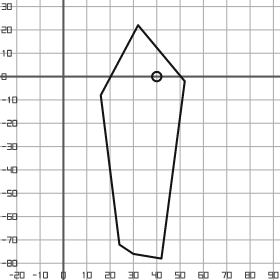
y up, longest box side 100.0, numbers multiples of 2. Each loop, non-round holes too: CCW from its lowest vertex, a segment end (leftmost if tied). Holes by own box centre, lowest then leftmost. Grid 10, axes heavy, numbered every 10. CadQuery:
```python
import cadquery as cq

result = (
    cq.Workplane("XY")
    .moveTo(42.0, -78.0)
    .lineTo(52.0, -2.0)
    .lineTo(32.0, 22.0)
    .lineTo(16.0, -8.0)
    .lineTo(24.0, -72.0)
    .lineTo(30.0, -76.0)
    .close()
    .moveTo(40.0, 0.0)
    .circle(2.0)
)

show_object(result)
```